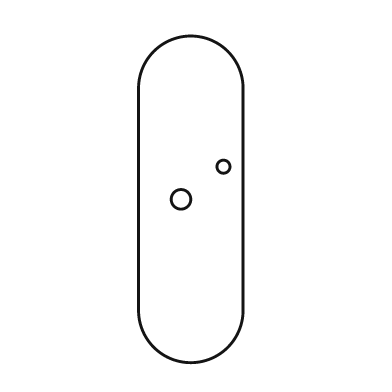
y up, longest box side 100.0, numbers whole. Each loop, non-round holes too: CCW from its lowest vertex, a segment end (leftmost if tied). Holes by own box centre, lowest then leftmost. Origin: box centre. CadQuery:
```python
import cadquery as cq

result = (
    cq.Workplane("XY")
    .moveTo(-16.0, -34.0)
    .threePointArc((0.0, -50.0), (16.0, -34.0))
    .lineTo(16.0, 34.0)
    .threePointArc((0.0, 50.0), (-16.0, 34.0))
    .close()
    .moveTo(-3.0, 0.0)
    .circle(3.0)
    .moveTo(10.0, 10.0)
    .circle(2.0)
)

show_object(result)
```